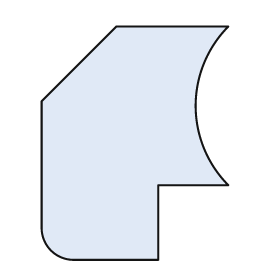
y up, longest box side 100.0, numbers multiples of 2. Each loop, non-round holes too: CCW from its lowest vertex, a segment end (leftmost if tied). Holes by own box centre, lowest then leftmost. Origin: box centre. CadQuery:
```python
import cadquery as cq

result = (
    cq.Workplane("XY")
    .moveTo(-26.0, -50.0)
    .lineTo(10.0, -50.0)
    .lineTo(10.0, -18.0)
    .lineTo(40.0, -18.0)
    .threePointArc((26.0, 16.0), (40.0, 50.0))
    .lineTo(-8.0, 50.0)
    .lineTo(-40.0, 18.0)
    .lineTo(-40.0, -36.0)
    .threePointArc((-36.0, -46.0), (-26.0, -50.0))
    .close()
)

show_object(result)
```